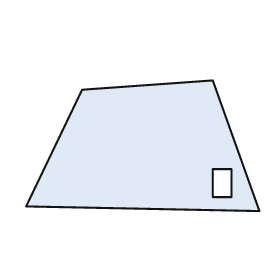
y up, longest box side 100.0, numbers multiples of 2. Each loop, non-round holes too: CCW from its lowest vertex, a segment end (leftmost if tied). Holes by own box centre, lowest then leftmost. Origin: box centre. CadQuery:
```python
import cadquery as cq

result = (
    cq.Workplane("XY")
    .moveTo(50.0, -28.0)
    .lineTo(30.0, 28.0)
    .lineTo(-26.0, 24.0)
    .lineTo(-50.0, -26.0)
    .close()
    .moveTo(30.0, -22.0)
    .lineTo(38.0, -22.0)
    .lineTo(38.0, -10.0)
    .lineTo(30.0, -10.0)
    .close()
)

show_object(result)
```